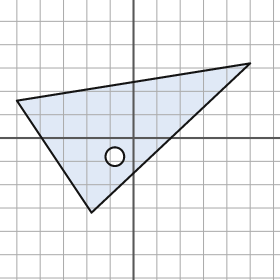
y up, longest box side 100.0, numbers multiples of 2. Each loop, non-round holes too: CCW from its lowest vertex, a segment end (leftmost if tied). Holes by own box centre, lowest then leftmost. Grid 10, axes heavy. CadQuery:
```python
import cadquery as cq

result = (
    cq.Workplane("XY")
    .moveTo(-18.0, -32.0)
    .lineTo(50.0, 32.0)
    .lineTo(-50.0, 16.0)
    .close()
    .moveTo(-8.0, -8.0)
    .circle(4.0)
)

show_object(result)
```